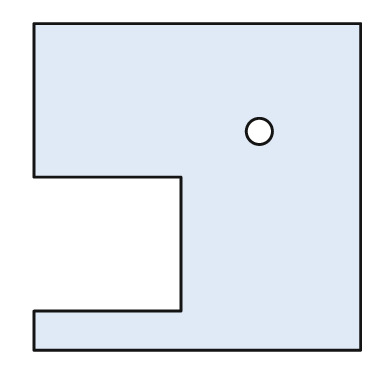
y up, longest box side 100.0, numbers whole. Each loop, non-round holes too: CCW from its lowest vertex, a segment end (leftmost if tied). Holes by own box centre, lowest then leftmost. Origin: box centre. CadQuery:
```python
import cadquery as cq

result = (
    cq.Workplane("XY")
    .moveTo(-50.0, -50.0)
    .lineTo(50.0, -50.0)
    .lineTo(50.0, 50.0)
    .lineTo(-50.0, 50.0)
    .lineTo(-50.0, 3.0)
    .lineTo(-5.0, 3.0)
    .lineTo(-5.0, -38.0)
    .lineTo(-50.0, -38.0)
    .close()
    .moveTo(19.0, 17.0)
    .circle(4.0)
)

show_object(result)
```